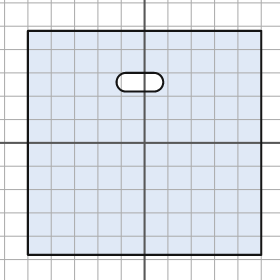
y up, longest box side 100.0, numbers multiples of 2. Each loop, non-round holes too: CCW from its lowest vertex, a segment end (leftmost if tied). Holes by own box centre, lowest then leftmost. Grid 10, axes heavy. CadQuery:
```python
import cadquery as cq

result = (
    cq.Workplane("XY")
    .moveTo(-50.0, -48.0)
    .lineTo(50.0, -48.0)
    .lineTo(50.0, 48.0)
    .lineTo(-50.0, 48.0)
    .close()
    .moveTo(-8.0, 22.0)
    .lineTo(4.0, 22.0)
    .threePointArc((8.0, 26.0), (4.0, 30.0))
    .lineTo(-8.0, 30.0)
    .threePointArc((-12.0, 26.0), (-8.0, 22.0))
    .close()
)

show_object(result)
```